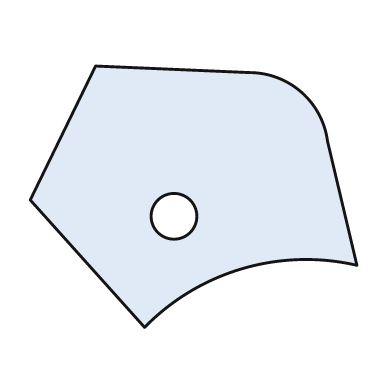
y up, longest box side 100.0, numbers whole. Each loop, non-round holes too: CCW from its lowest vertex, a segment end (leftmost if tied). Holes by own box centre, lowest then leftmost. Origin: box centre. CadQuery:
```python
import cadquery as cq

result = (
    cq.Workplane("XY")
    .moveTo(-15.0, -40.0)
    .threePointArc((15.0, -22.0), (50.0, -21.0))
    .lineTo(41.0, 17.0)
    .threePointArc((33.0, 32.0), (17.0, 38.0))
    .lineTo(-30.0, 40.0)
    .lineTo(-50.0, -1.0)
    .close()
    .moveTo(-6.0, -6.0)
    .circle(7.0)
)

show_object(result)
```